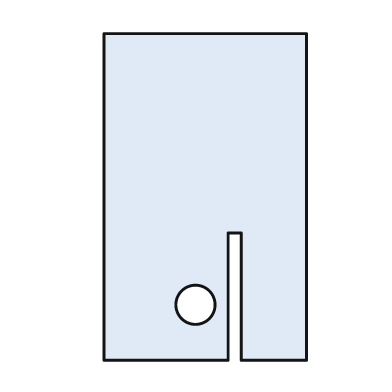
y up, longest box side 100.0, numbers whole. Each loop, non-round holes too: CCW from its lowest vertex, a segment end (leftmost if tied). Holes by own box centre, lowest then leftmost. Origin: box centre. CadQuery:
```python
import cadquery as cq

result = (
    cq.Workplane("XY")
    .moveTo(-31.0, -50.0)
    .lineTo(7.0, -50.0)
    .lineTo(7.0, -11.0)
    .lineTo(11.0, -11.0)
    .lineTo(11.0, -50.0)
    .lineTo(31.0, -50.0)
    .lineTo(31.0, 50.0)
    .lineTo(-31.0, 50.0)
    .close()
    .moveTo(-3.0, -33.0)
    .circle(6.0)
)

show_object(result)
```